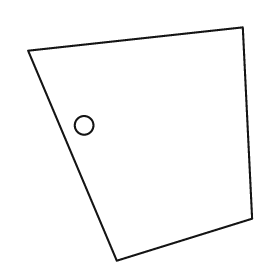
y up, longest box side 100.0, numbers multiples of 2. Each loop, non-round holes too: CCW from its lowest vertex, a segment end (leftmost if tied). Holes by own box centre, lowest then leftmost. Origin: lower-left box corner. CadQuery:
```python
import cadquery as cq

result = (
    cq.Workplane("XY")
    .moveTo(38.0, 0.0)
    .lineTo(96.0, 18.0)
    .lineTo(92.0, 100.0)
    .lineTo(0.0, 90.0)
    .close()
    .moveTo(24.0, 58.0)
    .circle(4.0)
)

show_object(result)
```